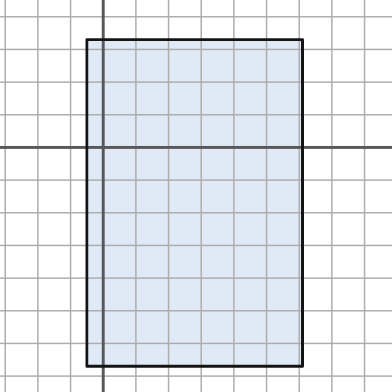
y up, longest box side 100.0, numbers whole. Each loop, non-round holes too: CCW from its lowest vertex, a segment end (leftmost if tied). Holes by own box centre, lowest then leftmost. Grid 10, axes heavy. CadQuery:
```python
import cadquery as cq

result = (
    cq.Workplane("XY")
    .moveTo(-5.0, -67.0)
    .lineTo(61.0, -67.0)
    .lineTo(61.0, 33.0)
    .lineTo(-5.0, 33.0)
    .close()
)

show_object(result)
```